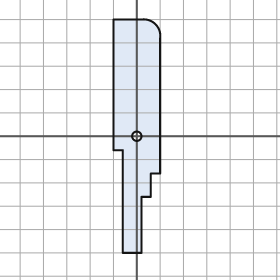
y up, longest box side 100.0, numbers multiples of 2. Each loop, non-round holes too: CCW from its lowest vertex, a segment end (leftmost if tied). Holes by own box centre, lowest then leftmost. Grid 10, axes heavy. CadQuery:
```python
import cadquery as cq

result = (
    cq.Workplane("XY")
    .moveTo(-6.0, -50.0)
    .lineTo(2.0, -50.0)
    .lineTo(2.0, -26.0)
    .lineTo(6.0, -26.0)
    .lineTo(6.0, -16.0)
    .lineTo(10.0, -16.0)
    .lineTo(10.0, 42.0)
    .threePointArc((8.0, 48.0), (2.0, 50.0))
    .lineTo(-10.0, 50.0)
    .lineTo(-10.0, -6.0)
    .lineTo(-6.0, -6.0)
    .close()
    .moveTo(0.0, 0.0)
    .circle(2.0)
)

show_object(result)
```